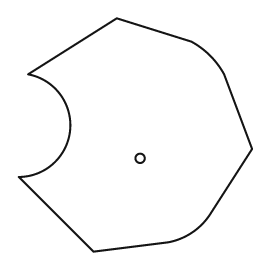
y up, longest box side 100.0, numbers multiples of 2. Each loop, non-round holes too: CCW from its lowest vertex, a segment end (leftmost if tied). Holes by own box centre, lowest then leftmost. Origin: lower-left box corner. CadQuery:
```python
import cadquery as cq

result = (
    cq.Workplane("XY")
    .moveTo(32.0, 0.0)
    .lineTo(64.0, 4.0)
    .threePointArc((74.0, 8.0), (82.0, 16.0))
    .lineTo(100.0, 44.0)
    .lineTo(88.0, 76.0)
    .threePointArc((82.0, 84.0), (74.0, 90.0))
    .lineTo(42.0, 100.0)
    .lineTo(4.0, 76.0)
    .threePointArc((22.0, 52.0), (0.0, 32.0))
    .close()
    .moveTo(52.0, 40.0)
    .circle(2.0)
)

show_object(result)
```